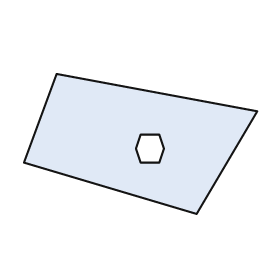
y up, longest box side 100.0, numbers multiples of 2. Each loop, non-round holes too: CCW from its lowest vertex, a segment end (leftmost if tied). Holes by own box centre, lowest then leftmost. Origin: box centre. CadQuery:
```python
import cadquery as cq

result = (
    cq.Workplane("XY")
    .moveTo(24.0, -30.0)
    .lineTo(50.0, 14.0)
    .lineTo(-36.0, 30.0)
    .lineTo(-50.0, -8.0)
    .close()
    .moveTo(0.0, -8.0)
    .lineTo(8.0, -8.0)
    .lineTo(10.0, -2.0)
    .lineTo(8.0, 4.0)
    .lineTo(0.0, 4.0)
    .lineTo(-2.0, -2.0)
    .close()
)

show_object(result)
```